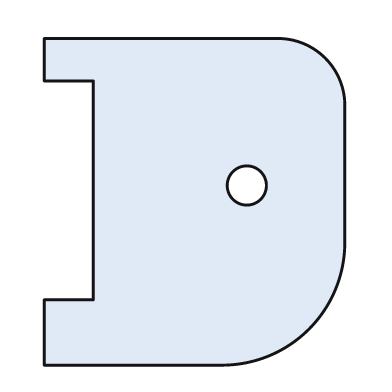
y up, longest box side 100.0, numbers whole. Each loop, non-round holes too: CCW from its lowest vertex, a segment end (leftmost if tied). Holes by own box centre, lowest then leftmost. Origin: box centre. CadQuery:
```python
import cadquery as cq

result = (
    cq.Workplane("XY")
    .moveTo(-46.0, -50.0)
    .lineTo(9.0, -50.0)
    .threePointArc((35.0, -39.0), (46.0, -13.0))
    .lineTo(46.0, 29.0)
    .threePointArc((40.0, 44.0), (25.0, 50.0))
    .lineTo(-46.0, 50.0)
    .lineTo(-46.0, 37.0)
    .lineTo(-31.0, 37.0)
    .lineTo(-31.0, -30.0)
    .lineTo(-46.0, -30.0)
    .close()
    .moveTo(16.0, 5.0)
    .circle(6.0)
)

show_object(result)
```